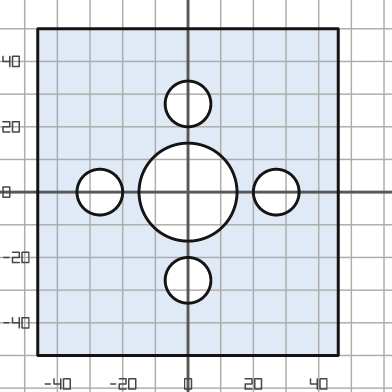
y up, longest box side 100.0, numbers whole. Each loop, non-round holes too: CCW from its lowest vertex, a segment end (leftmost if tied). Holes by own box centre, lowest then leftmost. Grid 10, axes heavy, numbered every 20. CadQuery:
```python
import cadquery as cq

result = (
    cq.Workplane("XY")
    .moveTo(-46.0, -50.0)
    .lineTo(46.0, -50.0)
    .lineTo(46.0, 50.0)
    .lineTo(-46.0, 50.0)
    .close()
    .moveTo(0.0, -27.0)
    .circle(7.0)
    .moveTo(-27.0, 0.0)
    .circle(7.0)
    .moveTo(0.0, 0.0)
    .circle(15.0)
    .moveTo(27.0, 0.0)
    .circle(7.0)
    .moveTo(0.0, 27.0)
    .circle(7.0)
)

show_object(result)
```